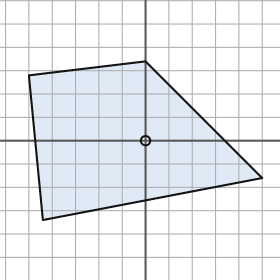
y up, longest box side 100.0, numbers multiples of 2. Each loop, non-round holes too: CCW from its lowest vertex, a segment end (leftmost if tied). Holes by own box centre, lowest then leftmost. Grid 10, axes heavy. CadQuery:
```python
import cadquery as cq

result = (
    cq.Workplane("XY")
    .moveTo(-44.0, -34.0)
    .lineTo(50.0, -16.0)
    .lineTo(0.0, 34.0)
    .lineTo(-50.0, 28.0)
    .close()
    .moveTo(0.0, 0.0)
    .circle(2.0)
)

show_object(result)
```